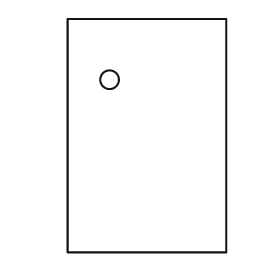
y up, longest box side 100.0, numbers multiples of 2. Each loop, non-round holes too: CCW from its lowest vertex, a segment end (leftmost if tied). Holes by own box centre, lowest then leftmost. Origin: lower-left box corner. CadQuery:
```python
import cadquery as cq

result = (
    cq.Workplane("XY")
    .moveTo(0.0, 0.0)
    .lineTo(68.0, 0.0)
    .lineTo(68.0, 100.0)
    .lineTo(0.0, 100.0)
    .close()
    .moveTo(18.0, 74.0)
    .circle(4.0)
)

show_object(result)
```